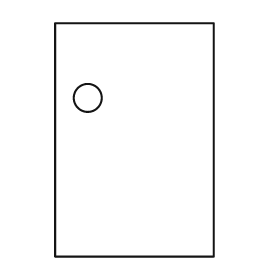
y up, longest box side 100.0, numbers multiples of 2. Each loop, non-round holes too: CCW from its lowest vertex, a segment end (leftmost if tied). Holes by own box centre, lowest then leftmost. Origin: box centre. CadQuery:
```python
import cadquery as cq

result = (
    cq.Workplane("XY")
    .moveTo(-34.0, -50.0)
    .lineTo(34.0, -50.0)
    .lineTo(34.0, 50.0)
    .lineTo(-34.0, 50.0)
    .close()
    .moveTo(-20.0, 18.0)
    .circle(6.0)
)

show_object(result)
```